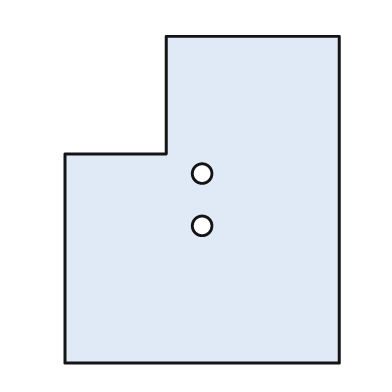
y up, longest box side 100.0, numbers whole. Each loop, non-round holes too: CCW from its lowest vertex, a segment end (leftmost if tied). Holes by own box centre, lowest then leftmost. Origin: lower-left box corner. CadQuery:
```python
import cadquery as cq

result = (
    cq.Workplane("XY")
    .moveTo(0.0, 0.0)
    .lineTo(84.0, 0.0)
    .lineTo(84.0, 100.0)
    .lineTo(31.0, 100.0)
    .lineTo(31.0, 64.0)
    .lineTo(0.0, 64.0)
    .close()
    .moveTo(42.0, 42.0)
    .circle(3.0)
    .moveTo(42.0, 58.0)
    .circle(3.0)
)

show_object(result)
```